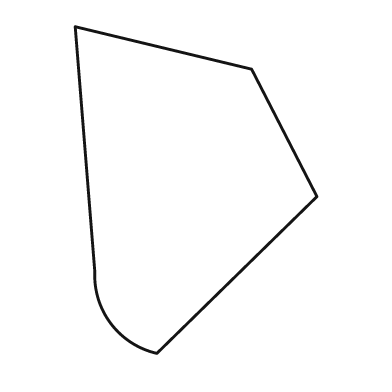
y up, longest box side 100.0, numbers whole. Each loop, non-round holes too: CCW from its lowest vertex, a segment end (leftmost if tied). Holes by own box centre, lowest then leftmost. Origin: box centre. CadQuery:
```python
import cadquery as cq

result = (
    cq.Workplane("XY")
    .moveTo(-12.0, -50.0)
    .lineTo(37.0, -2.0)
    .lineTo(17.0, 37.0)
    .lineTo(-37.0, 50.0)
    .lineTo(-31.0, -25.0)
    .threePointArc((-26.0, -41.0), (-12.0, -50.0))
    .close()
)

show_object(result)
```